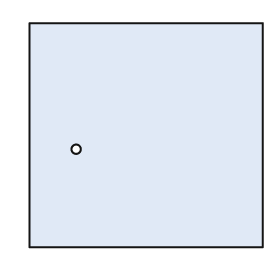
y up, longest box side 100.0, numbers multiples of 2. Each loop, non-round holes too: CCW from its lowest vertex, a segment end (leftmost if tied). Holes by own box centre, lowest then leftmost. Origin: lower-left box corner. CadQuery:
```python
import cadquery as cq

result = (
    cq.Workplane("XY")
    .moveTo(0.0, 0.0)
    .lineTo(100.0, 0.0)
    .lineTo(100.0, 96.0)
    .lineTo(0.0, 96.0)
    .close()
    .moveTo(20.0, 42.0)
    .circle(2.0)
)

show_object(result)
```